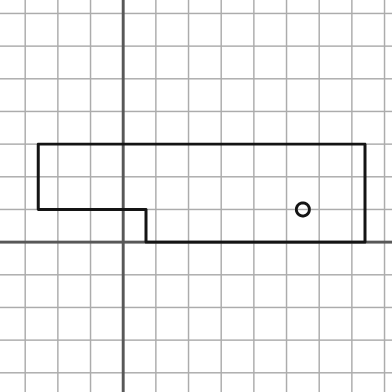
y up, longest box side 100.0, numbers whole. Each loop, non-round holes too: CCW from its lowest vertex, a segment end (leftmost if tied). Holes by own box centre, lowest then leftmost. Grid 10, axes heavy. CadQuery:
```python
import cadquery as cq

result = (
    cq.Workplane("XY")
    .moveTo(7.0, 0.0)
    .lineTo(74.0, 0.0)
    .lineTo(74.0, 30.0)
    .lineTo(-26.0, 30.0)
    .lineTo(-26.0, 10.0)
    .lineTo(7.0, 10.0)
    .close()
    .moveTo(55.0, 10.0)
    .circle(2.0)
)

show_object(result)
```